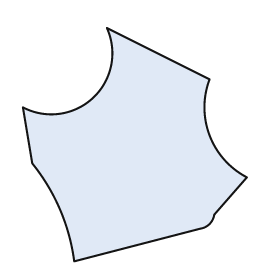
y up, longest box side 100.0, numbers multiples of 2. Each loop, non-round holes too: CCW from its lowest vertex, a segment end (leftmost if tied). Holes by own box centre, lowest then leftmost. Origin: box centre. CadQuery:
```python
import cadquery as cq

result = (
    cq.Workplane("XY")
    .moveTo(-26.0, -50.0)
    .lineTo(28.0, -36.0)
    .threePointArc((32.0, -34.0), (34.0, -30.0))
    .lineTo(48.0, -14.0)
    .threePointArc((32.0, 4.0), (32.0, 28.0))
    .lineTo(-12.0, 50.0)
    .threePointArc((-18.0, 20.0), (-48.0, 16.0))
    .lineTo(-44.0, -8.0)
    .threePointArc((-32.0, -28.0), (-26.0, -50.0))
    .close()
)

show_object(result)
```